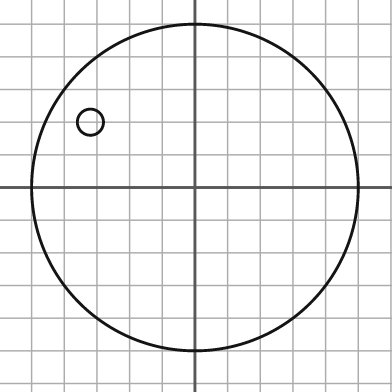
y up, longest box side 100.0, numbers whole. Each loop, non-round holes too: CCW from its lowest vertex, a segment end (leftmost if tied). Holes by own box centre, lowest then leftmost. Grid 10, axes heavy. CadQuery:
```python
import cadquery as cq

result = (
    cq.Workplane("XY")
    .moveTo(0.0, 0.0)
    .circle(50.0)
    .moveTo(-32.0, 20.0)
    .circle(4.0)
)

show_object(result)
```